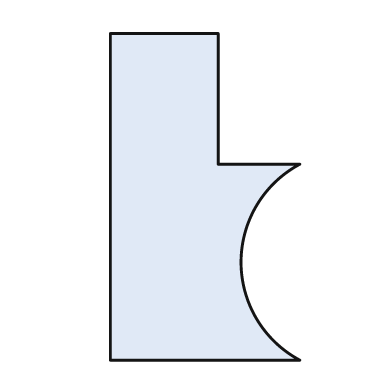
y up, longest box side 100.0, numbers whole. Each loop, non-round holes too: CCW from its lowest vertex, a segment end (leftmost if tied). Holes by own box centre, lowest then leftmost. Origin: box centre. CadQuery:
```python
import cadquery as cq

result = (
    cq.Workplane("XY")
    .moveTo(-29.0, -50.0)
    .lineTo(29.0, -50.0)
    .threePointArc((11.0, -20.0), (29.0, 10.0))
    .lineTo(4.0, 10.0)
    .lineTo(4.0, 50.0)
    .lineTo(-29.0, 50.0)
    .close()
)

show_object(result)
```